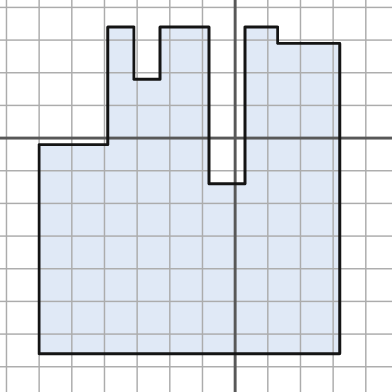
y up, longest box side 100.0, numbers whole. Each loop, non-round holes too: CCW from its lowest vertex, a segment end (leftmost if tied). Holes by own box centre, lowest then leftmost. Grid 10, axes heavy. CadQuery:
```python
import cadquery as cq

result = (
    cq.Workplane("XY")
    .moveTo(-60.0, -66.0)
    .lineTo(32.0, -66.0)
    .lineTo(32.0, 29.0)
    .lineTo(13.0, 29.0)
    .lineTo(13.0, 34.0)
    .lineTo(3.0, 34.0)
    .lineTo(3.0, -14.0)
    .lineTo(-8.0, -14.0)
    .lineTo(-8.0, 34.0)
    .lineTo(-23.0, 34.0)
    .lineTo(-23.0, 18.0)
    .lineTo(-31.0, 18.0)
    .lineTo(-31.0, 34.0)
    .lineTo(-39.0, 34.0)
    .lineTo(-39.0, -2.0)
    .lineTo(-60.0, -2.0)
    .close()
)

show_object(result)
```